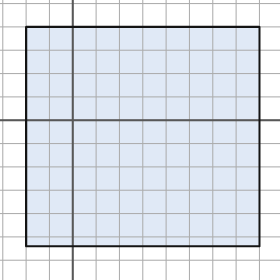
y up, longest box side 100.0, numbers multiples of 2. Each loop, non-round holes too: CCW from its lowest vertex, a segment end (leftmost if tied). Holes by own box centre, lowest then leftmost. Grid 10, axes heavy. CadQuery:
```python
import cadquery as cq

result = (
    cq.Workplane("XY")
    .moveTo(-20.0, -54.0)
    .lineTo(80.0, -54.0)
    .lineTo(80.0, 40.0)
    .lineTo(-20.0, 40.0)
    .close()
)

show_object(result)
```